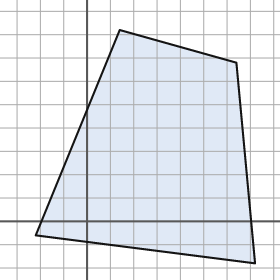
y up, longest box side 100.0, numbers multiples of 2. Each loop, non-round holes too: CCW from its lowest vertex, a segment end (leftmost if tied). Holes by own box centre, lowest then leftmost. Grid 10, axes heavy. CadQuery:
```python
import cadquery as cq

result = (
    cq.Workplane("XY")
    .moveTo(72.0, -18.0)
    .lineTo(64.0, 68.0)
    .lineTo(14.0, 82.0)
    .lineTo(-22.0, -6.0)
    .close()
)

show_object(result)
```